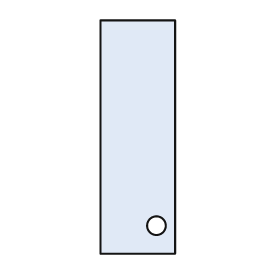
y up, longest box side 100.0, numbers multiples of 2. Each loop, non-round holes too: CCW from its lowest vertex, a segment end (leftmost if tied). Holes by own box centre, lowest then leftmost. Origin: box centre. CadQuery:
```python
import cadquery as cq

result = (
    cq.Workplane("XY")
    .moveTo(-16.0, -50.0)
    .lineTo(16.0, -50.0)
    .lineTo(16.0, 50.0)
    .lineTo(-16.0, 50.0)
    .close()
    .moveTo(8.0, -38.0)
    .circle(4.0)
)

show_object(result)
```